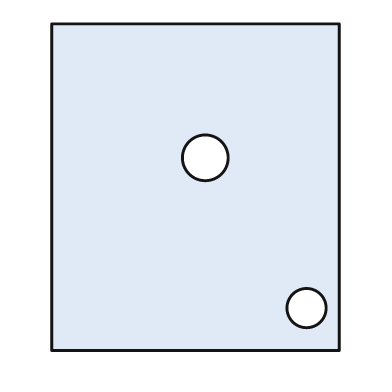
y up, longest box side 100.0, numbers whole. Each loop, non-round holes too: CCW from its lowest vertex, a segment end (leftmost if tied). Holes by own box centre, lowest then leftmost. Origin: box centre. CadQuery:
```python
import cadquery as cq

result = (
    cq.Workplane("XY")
    .moveTo(-44.0, -50.0)
    .lineTo(44.0, -50.0)
    .lineTo(44.0, 50.0)
    .lineTo(-44.0, 50.0)
    .close()
    .moveTo(34.0, -37.0)
    .circle(6.0)
    .moveTo(3.0, 9.0)
    .circle(7.0)
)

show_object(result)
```